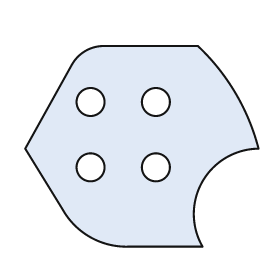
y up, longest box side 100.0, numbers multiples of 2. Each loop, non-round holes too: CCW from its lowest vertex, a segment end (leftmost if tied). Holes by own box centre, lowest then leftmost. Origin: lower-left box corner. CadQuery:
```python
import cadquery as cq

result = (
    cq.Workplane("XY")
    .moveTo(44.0, 0.0)
    .lineTo(76.0, 0.0)
    .threePointArc((76.0, 28.0), (100.0, 42.0))
    .threePointArc((90.0, 66.0), (74.0, 86.0))
    .lineTo(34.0, 86.0)
    .threePointArc((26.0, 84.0), (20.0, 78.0))
    .lineTo(0.0, 42.0)
    .lineTo(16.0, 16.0)
    .threePointArc((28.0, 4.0), (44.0, 0.0))
    .close()
    .moveTo(28.0, 34.0)
    .circle(6.0)
    .moveTo(56.0, 34.0)
    .circle(6.0)
    .moveTo(28.0, 62.0)
    .circle(6.0)
    .moveTo(56.0, 62.0)
    .circle(6.0)
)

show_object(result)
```